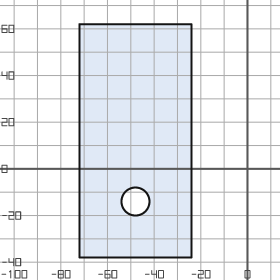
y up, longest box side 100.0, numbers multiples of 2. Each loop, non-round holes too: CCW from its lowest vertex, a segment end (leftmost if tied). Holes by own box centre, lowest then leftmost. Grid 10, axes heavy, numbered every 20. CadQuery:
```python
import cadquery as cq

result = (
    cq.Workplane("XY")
    .moveTo(-72.0, -38.0)
    .lineTo(-24.0, -38.0)
    .lineTo(-24.0, 62.0)
    .lineTo(-72.0, 62.0)
    .close()
    .moveTo(-48.0, -14.0)
    .circle(6.0)
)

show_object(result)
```